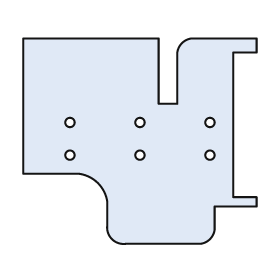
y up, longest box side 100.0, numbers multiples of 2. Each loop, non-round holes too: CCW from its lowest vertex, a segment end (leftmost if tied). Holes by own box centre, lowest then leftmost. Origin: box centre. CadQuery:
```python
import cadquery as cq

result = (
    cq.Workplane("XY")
    .moveTo(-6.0, -44.0)
    .lineTo(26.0, -44.0)
    .threePointArc((30.0, -42.0), (32.0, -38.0))
    .lineTo(32.0, -28.0)
    .lineTo(50.0, -28.0)
    .lineTo(50.0, -24.0)
    .lineTo(40.0, -24.0)
    .lineTo(40.0, 38.0)
    .lineTo(50.0, 38.0)
    .lineTo(50.0, 44.0)
    .lineTo(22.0, 44.0)
    .threePointArc((18.0, 42.0), (16.0, 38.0))
    .lineTo(16.0, 16.0)
    .lineTo(8.0, 16.0)
    .lineTo(8.0, 44.0)
    .lineTo(-50.0, 44.0)
    .lineTo(-50.0, -14.0)
    .lineTo(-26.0, -14.0)
    .threePointArc((-18.0, -18.0), (-14.0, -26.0))
    .lineTo(-14.0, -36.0)
    .threePointArc((-12.0, -42.0), (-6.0, -44.0))
    .close()
    .moveTo(-30.0, -6.0)
    .circle(2.0)
    .moveTo(0.0, -6.0)
    .circle(2.0)
    .moveTo(30.0, -6.0)
    .circle(2.0)
    .moveTo(-30.0, 8.0)
    .circle(2.0)
    .moveTo(0.0, 8.0)
    .circle(2.0)
    .moveTo(30.0, 8.0)
    .circle(2.0)
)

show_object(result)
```